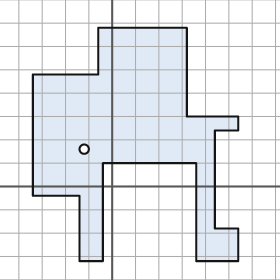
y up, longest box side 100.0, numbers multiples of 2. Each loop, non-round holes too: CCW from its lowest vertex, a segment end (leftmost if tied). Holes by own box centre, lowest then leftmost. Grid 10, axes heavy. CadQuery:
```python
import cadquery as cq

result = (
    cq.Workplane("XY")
    .moveTo(-14.0, -32.0)
    .lineTo(-4.0, -32.0)
    .lineTo(-4.0, 10.0)
    .lineTo(36.0, 10.0)
    .lineTo(36.0, -32.0)
    .lineTo(54.0, -32.0)
    .lineTo(54.0, -18.0)
    .lineTo(44.0, -18.0)
    .lineTo(44.0, 24.0)
    .lineTo(54.0, 24.0)
    .lineTo(54.0, 30.0)
    .lineTo(32.0, 30.0)
    .lineTo(32.0, 68.0)
    .lineTo(-6.0, 68.0)
    .lineTo(-6.0, 48.0)
    .lineTo(-34.0, 48.0)
    .lineTo(-34.0, -4.0)
    .lineTo(-14.0, -4.0)
    .close()
    .moveTo(-12.0, 16.0)
    .circle(2.0)
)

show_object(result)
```